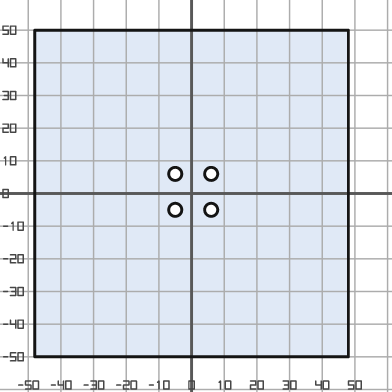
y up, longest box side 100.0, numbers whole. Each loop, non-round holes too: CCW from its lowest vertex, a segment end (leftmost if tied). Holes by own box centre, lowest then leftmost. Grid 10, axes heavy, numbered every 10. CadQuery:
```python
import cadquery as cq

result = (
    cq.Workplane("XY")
    .moveTo(-48.0, -50.0)
    .lineTo(48.0, -50.0)
    .lineTo(48.0, 50.0)
    .lineTo(-48.0, 50.0)
    .close()
    .moveTo(-5.0, -5.0)
    .circle(2.0)
    .moveTo(6.0, -5.0)
    .circle(2.0)
    .moveTo(-5.0, 6.0)
    .circle(2.0)
    .moveTo(6.0, 6.0)
    .circle(2.0)
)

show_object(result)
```